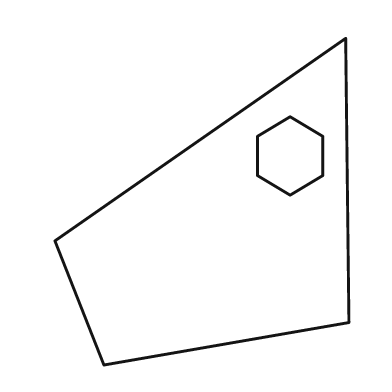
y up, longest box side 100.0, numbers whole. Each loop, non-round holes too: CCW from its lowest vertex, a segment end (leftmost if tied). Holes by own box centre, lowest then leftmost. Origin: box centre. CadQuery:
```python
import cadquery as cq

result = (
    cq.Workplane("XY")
    .moveTo(-30.0, -50.0)
    .lineTo(45.0, -37.0)
    .lineTo(44.0, 50.0)
    .lineTo(-45.0, -12.0)
    .close()
    .moveTo(27.0, 2.0)
    .lineTo(37.0, 8.0)
    .lineTo(37.0, 20.0)
    .lineTo(27.0, 26.0)
    .lineTo(17.0, 20.0)
    .lineTo(17.0, 8.0)
    .close()
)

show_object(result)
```